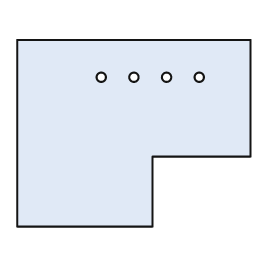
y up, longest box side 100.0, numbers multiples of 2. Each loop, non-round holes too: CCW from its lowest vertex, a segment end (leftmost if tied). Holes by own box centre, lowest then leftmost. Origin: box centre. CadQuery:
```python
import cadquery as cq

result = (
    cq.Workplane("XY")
    .moveTo(-50.0, -40.0)
    .lineTo(8.0, -40.0)
    .lineTo(8.0, -10.0)
    .lineTo(50.0, -10.0)
    .lineTo(50.0, 40.0)
    .lineTo(-50.0, 40.0)
    .close()
    .moveTo(-14.0, 24.0)
    .circle(2.0)
    .moveTo(0.0, 24.0)
    .circle(2.0)
    .moveTo(14.0, 24.0)
    .circle(2.0)
    .moveTo(28.0, 24.0)
    .circle(2.0)
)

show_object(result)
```